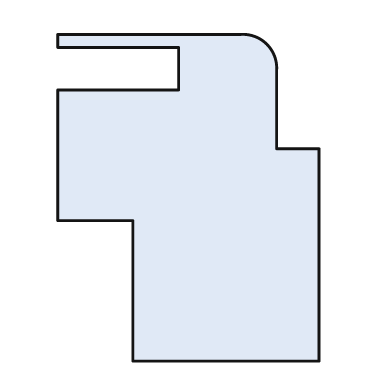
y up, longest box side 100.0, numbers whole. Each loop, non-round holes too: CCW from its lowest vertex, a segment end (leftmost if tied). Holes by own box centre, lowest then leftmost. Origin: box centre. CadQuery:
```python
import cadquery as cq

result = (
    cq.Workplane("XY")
    .moveTo(-17.0, -50.0)
    .lineTo(40.0, -50.0)
    .lineTo(40.0, 15.0)
    .lineTo(27.0, 15.0)
    .lineTo(27.0, 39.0)
    .threePointArc((24.0, 47.0), (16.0, 50.0))
    .lineTo(-40.0, 50.0)
    .lineTo(-40.0, 46.0)
    .lineTo(-3.0, 46.0)
    .lineTo(-3.0, 33.0)
    .lineTo(-40.0, 33.0)
    .lineTo(-40.0, -7.0)
    .lineTo(-17.0, -7.0)
    .close()
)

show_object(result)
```